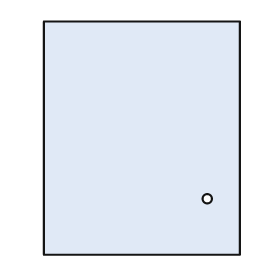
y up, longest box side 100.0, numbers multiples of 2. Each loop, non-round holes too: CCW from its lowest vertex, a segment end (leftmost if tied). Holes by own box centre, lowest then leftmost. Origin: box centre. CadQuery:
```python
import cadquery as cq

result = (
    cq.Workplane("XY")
    .moveTo(-42.0, -50.0)
    .lineTo(42.0, -50.0)
    .lineTo(42.0, 50.0)
    .lineTo(-42.0, 50.0)
    .close()
    .moveTo(28.0, -26.0)
    .circle(2.0)
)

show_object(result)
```